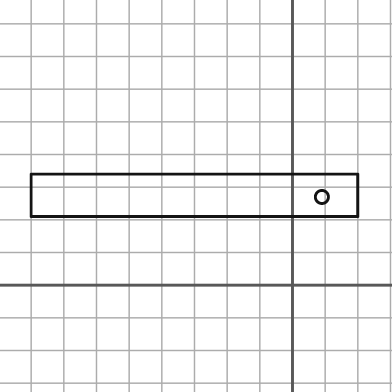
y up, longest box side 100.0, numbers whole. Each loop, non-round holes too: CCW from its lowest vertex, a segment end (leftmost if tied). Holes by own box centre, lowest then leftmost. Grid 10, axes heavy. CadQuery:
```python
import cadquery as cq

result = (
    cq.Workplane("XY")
    .moveTo(-80.0, 21.0)
    .lineTo(20.0, 21.0)
    .lineTo(20.0, 34.0)
    .lineTo(-80.0, 34.0)
    .close()
    .moveTo(9.0, 27.0)
    .circle(2.0)
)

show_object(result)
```